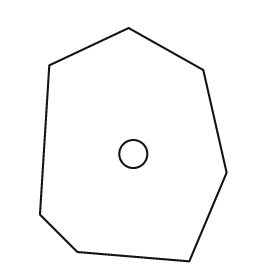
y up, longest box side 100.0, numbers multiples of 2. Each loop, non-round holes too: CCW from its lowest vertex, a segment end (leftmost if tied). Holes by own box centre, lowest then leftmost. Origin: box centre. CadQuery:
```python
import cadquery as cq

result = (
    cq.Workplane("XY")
    .moveTo(24.0, -50.0)
    .lineTo(40.0, -12.0)
    .lineTo(30.0, 32.0)
    .lineTo(-2.0, 50.0)
    .lineTo(-36.0, 34.0)
    .lineTo(-40.0, -30.0)
    .lineTo(-24.0, -46.0)
    .close()
    .moveTo(0.0, -4.0)
    .circle(6.0)
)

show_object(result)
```